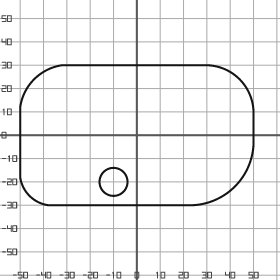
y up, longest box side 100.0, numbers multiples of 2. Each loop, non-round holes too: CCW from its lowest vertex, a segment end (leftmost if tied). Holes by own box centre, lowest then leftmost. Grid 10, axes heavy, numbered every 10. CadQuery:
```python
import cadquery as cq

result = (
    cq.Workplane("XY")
    .moveTo(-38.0, -30.0)
    .lineTo(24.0, -30.0)
    .threePointArc((42.0, -22.0), (50.0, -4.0))
    .lineTo(50.0, 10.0)
    .threePointArc((44.0, 24.0), (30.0, 30.0))
    .lineTo(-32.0, 30.0)
    .threePointArc((-44.0, 24.0), (-50.0, 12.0))
    .lineTo(-50.0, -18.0)
    .threePointArc((-46.0, -26.0), (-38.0, -30.0))
    .close()
    .moveTo(-10.0, -20.0)
    .circle(6.0)
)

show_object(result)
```